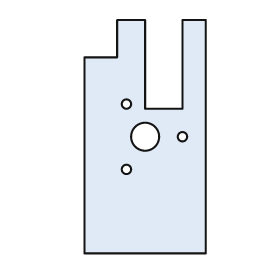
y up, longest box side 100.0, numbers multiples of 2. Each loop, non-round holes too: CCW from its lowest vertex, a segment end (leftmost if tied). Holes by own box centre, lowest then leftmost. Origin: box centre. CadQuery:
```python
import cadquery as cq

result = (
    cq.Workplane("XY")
    .moveTo(-26.0, -50.0)
    .lineTo(26.0, -50.0)
    .lineTo(26.0, 50.0)
    .lineTo(16.0, 50.0)
    .lineTo(16.0, 12.0)
    .lineTo(0.0, 12.0)
    .lineTo(0.0, 50.0)
    .lineTo(-12.0, 50.0)
    .lineTo(-12.0, 34.0)
    .lineTo(-26.0, 34.0)
    .close()
    .moveTo(-8.0, -14.0)
    .circle(2.0)
    .moveTo(0.0, 0.0)
    .circle(6.0)
    .moveTo(16.0, 0.0)
    .circle(2.0)
    .moveTo(-8.0, 14.0)
    .circle(2.0)
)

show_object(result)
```